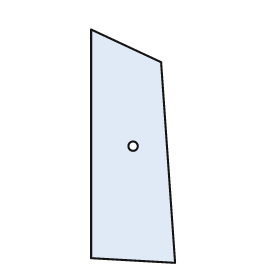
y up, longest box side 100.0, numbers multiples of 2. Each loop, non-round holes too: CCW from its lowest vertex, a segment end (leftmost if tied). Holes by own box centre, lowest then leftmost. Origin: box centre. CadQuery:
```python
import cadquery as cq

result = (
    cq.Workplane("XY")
    .moveTo(18.0, -50.0)
    .lineTo(12.0, 36.0)
    .lineTo(-18.0, 50.0)
    .lineTo(-18.0, -48.0)
    .close()
    .moveTo(0.0, 0.0)
    .circle(2.0)
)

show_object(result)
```